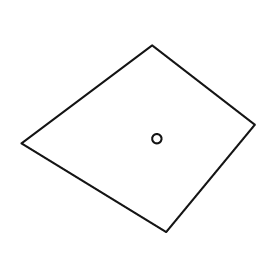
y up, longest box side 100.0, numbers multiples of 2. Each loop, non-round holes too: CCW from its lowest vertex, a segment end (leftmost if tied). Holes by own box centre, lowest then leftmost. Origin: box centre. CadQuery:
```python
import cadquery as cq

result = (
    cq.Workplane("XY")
    .moveTo(12.0, -40.0)
    .lineTo(50.0, 6.0)
    .lineTo(6.0, 40.0)
    .lineTo(-50.0, -2.0)
    .close()
    .moveTo(8.0, 0.0)
    .circle(2.0)
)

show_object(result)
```